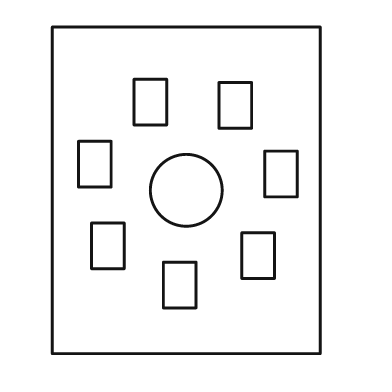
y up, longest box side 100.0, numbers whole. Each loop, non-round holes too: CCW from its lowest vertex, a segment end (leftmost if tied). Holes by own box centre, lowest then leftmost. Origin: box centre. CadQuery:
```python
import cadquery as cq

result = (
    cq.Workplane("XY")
    .moveTo(-41.0, -50.0)
    .lineTo(41.0, -50.0)
    .lineTo(41.0, 50.0)
    .lineTo(-41.0, 50.0)
    .close()
    .moveTo(-7.0, -36.0)
    .lineTo(3.0, -36.0)
    .lineTo(3.0, -22.0)
    .lineTo(-7.0, -22.0)
    .close()
    .moveTo(17.0, -27.0)
    .lineTo(27.0, -27.0)
    .lineTo(27.0, -13.0)
    .lineTo(17.0, -13.0)
    .close()
    .moveTo(-29.0, -24.0)
    .lineTo(-19.0, -24.0)
    .lineTo(-19.0, -10.0)
    .lineTo(-29.0, -10.0)
    .close()
    .moveTo(0.0, 0.0)
    .circle(11.0)
    .moveTo(24.0, -2.0)
    .lineTo(34.0, -2.0)
    .lineTo(34.0, 12.0)
    .lineTo(24.0, 12.0)
    .close()
    .moveTo(-33.0, 1.0)
    .lineTo(-23.0, 1.0)
    .lineTo(-23.0, 15.0)
    .lineTo(-33.0, 15.0)
    .close()
    .moveTo(10.0, 19.0)
    .lineTo(20.0, 19.0)
    .lineTo(20.0, 33.0)
    .lineTo(10.0, 33.0)
    .close()
    .moveTo(-16.0, 20.0)
    .lineTo(-6.0, 20.0)
    .lineTo(-6.0, 34.0)
    .lineTo(-16.0, 34.0)
    .close()
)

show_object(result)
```